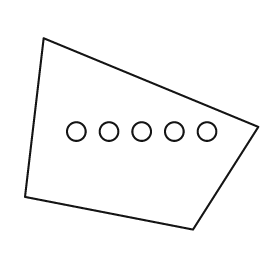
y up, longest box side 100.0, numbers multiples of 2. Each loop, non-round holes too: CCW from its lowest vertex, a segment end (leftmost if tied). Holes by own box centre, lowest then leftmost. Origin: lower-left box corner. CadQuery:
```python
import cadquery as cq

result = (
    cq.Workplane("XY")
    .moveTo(72.0, 0.0)
    .lineTo(100.0, 44.0)
    .lineTo(8.0, 82.0)
    .lineTo(0.0, 14.0)
    .close()
    .moveTo(22.0, 42.0)
    .circle(4.0)
    .moveTo(36.0, 42.0)
    .circle(4.0)
    .moveTo(50.0, 42.0)
    .circle(4.0)
    .moveTo(64.0, 42.0)
    .circle(4.0)
    .moveTo(78.0, 42.0)
    .circle(4.0)
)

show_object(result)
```